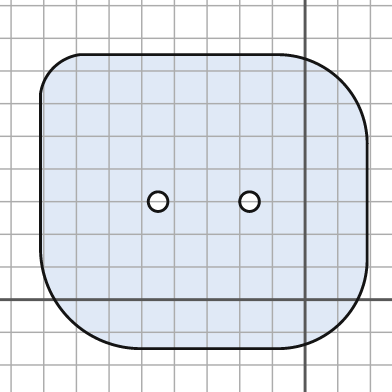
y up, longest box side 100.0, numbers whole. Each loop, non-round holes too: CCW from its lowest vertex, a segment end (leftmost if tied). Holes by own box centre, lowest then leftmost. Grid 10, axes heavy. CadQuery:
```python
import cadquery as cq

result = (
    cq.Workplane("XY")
    .moveTo(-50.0, -15.0)
    .lineTo(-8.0, -15.0)
    .threePointArc((11.0, -7.0), (19.0, 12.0))
    .lineTo(19.0, 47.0)
    .threePointArc((11.0, 67.0), (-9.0, 75.0))
    .lineTo(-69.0, 75.0)
    .threePointArc((-77.0, 71.0), (-81.0, 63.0))
    .lineTo(-81.0, 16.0)
    .threePointArc((-72.0, -6.0), (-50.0, -15.0))
    .close()
    .moveTo(-45.0, 30.0)
    .circle(3.0)
    .moveTo(-17.0, 30.0)
    .circle(3.0)
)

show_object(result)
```